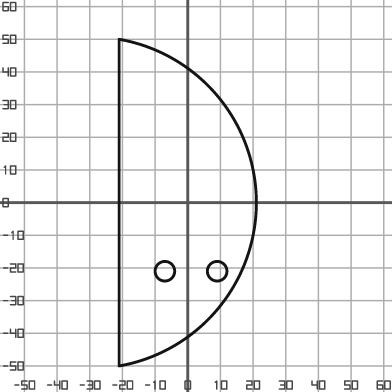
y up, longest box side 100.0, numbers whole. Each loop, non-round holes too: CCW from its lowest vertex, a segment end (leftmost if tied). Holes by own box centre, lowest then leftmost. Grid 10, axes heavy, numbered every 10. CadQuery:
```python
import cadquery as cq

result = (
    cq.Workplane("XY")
    .moveTo(-21.0, -50.0)
    .threePointArc((21.0, 0.0), (-21.0, 50.0))
    .close()
    .moveTo(-7.0, -21.0)
    .circle(3.0)
    .moveTo(9.0, -21.0)
    .circle(3.0)
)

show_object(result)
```